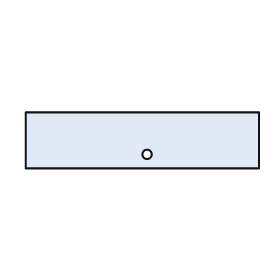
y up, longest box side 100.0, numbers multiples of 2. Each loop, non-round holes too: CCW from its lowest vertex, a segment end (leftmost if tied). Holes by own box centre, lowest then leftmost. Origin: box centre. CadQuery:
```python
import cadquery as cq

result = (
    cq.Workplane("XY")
    .moveTo(-50.0, -12.0)
    .lineTo(50.0, -12.0)
    .lineTo(50.0, 12.0)
    .lineTo(-50.0, 12.0)
    .close()
    .moveTo(2.0, -6.0)
    .circle(2.0)
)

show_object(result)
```